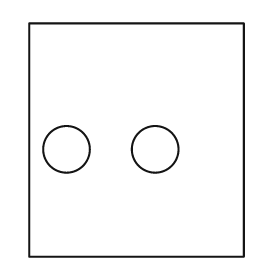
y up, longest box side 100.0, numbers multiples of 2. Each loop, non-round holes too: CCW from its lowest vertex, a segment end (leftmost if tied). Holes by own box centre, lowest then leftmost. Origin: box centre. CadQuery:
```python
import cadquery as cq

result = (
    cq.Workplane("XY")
    .moveTo(-46.0, -50.0)
    .lineTo(46.0, -50.0)
    .lineTo(46.0, 50.0)
    .lineTo(-46.0, 50.0)
    .close()
    .moveTo(-30.0, -4.0)
    .circle(10.0)
    .moveTo(8.0, -4.0)
    .circle(10.0)
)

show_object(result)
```